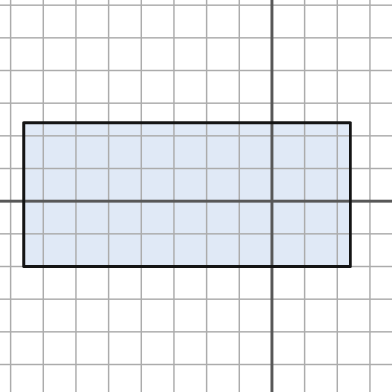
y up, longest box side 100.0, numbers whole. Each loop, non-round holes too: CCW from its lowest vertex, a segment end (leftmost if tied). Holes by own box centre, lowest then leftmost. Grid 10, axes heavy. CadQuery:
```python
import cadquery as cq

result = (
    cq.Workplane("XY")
    .moveTo(-76.0, -20.0)
    .lineTo(24.0, -20.0)
    .lineTo(24.0, 24.0)
    .lineTo(-76.0, 24.0)
    .close()
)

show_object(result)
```